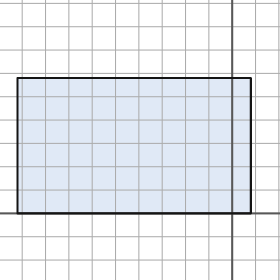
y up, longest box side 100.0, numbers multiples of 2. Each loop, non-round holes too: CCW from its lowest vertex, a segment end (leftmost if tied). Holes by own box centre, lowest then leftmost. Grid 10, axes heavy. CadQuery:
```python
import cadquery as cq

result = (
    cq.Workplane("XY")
    .moveTo(-92.0, 0.0)
    .lineTo(8.0, 0.0)
    .lineTo(8.0, 58.0)
    .lineTo(-92.0, 58.0)
    .close()
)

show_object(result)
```